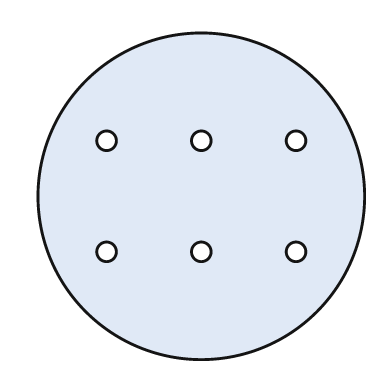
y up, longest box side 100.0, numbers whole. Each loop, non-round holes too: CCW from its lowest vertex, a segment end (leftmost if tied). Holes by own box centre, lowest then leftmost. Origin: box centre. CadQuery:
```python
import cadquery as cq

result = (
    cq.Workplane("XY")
    .moveTo(0.0, 0.0)
    .circle(50.0)
    .moveTo(-29.0, -17.0)
    .circle(3.0)
    .moveTo(0.0, -17.0)
    .circle(3.0)
    .moveTo(29.0, -17.0)
    .circle(3.0)
    .moveTo(-29.0, 17.0)
    .circle(3.0)
    .moveTo(0.0, 17.0)
    .circle(3.0)
    .moveTo(29.0, 17.0)
    .circle(3.0)
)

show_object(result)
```